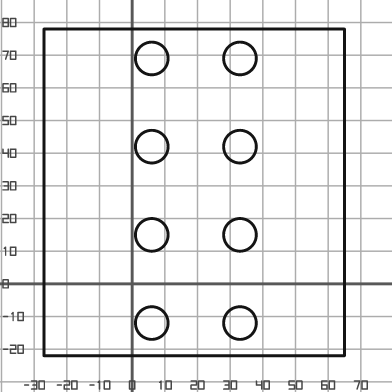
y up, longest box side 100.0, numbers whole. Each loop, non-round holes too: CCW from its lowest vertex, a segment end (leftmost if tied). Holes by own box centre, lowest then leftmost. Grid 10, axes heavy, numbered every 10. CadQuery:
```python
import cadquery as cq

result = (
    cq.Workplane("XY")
    .moveTo(-27.0, -22.0)
    .lineTo(65.0, -22.0)
    .lineTo(65.0, 78.0)
    .lineTo(-27.0, 78.0)
    .close()
    .moveTo(6.0, -12.0)
    .circle(5.0)
    .moveTo(33.0, -12.0)
    .circle(5.0)
    .moveTo(6.0, 15.0)
    .circle(5.0)
    .moveTo(33.0, 15.0)
    .circle(5.0)
    .moveTo(6.0, 42.0)
    .circle(5.0)
    .moveTo(33.0, 42.0)
    .circle(5.0)
    .moveTo(6.0, 69.0)
    .circle(5.0)
    .moveTo(33.0, 69.0)
    .circle(5.0)
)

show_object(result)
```